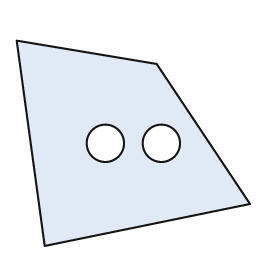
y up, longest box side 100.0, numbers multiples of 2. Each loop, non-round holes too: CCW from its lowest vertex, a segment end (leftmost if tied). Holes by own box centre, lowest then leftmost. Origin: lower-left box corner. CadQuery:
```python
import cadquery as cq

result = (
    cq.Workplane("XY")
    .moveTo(12.0, 0.0)
    .lineTo(100.0, 18.0)
    .lineTo(60.0, 78.0)
    .lineTo(0.0, 88.0)
    .close()
    .moveTo(38.0, 44.0)
    .circle(8.0)
    .moveTo(62.0, 44.0)
    .circle(8.0)
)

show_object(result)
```